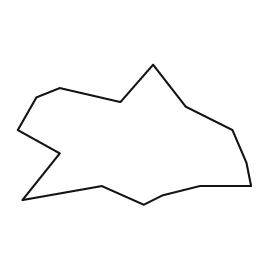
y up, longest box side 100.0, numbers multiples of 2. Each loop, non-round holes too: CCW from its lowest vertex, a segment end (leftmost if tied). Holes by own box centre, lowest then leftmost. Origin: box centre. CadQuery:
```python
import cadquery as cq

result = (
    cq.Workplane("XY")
    .moveTo(4.0, -30.0)
    .lineTo(12.0, -26.0)
    .lineTo(28.0, -22.0)
    .lineTo(50.0, -22.0)
    .lineTo(48.0, -12.0)
    .lineTo(42.0, 2.0)
    .lineTo(22.0, 12.0)
    .lineTo(8.0, 30.0)
    .lineTo(-6.0, 14.0)
    .lineTo(-32.0, 20.0)
    .lineTo(-42.0, 16.0)
    .lineTo(-50.0, 2.0)
    .lineTo(-32.0, -8.0)
    .lineTo(-48.0, -28.0)
    .lineTo(-14.0, -22.0)
    .close()
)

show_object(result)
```